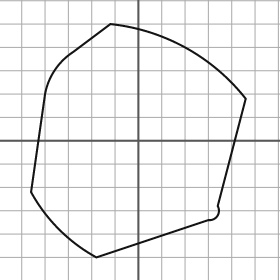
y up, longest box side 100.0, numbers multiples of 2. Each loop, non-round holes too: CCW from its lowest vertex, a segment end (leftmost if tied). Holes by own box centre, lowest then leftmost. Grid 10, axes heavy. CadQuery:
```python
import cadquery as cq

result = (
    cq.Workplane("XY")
    .moveTo(-18.0, -50.0)
    .lineTo(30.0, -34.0)
    .threePointArc((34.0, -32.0), (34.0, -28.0))
    .lineTo(46.0, 18.0)
    .threePointArc((20.0, 40.0), (-12.0, 50.0))
    .lineTo(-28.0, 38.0)
    .threePointArc((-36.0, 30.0), (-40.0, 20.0))
    .lineTo(-46.0, -22.0)
    .threePointArc((-34.0, -38.0), (-18.0, -50.0))
    .close()
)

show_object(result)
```